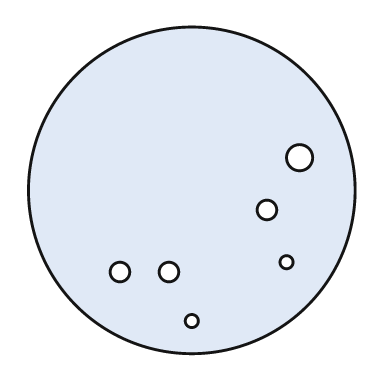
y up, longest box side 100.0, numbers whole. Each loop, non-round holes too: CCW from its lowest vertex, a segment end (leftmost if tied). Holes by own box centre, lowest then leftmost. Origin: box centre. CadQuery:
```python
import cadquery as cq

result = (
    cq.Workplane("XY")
    .moveTo(0.0, 0.0)
    .circle(50.0)
    .moveTo(0.0, -40.0)
    .circle(2.0)
    .moveTo(-22.0, -25.0)
    .circle(3.0)
    .moveTo(-7.0, -25.0)
    .circle(3.0)
    .moveTo(29.0, -22.0)
    .circle(2.0)
    .moveTo(23.0, -6.0)
    .circle(3.0)
    .moveTo(33.0, 10.0)
    .circle(4.0)
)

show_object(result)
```